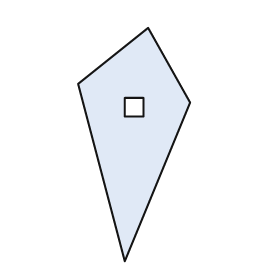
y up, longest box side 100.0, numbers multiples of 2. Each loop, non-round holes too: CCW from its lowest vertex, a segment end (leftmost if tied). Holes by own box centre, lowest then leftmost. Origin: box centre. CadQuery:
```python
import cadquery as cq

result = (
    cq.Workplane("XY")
    .moveTo(-4.0, -50.0)
    .lineTo(24.0, 18.0)
    .lineTo(6.0, 50.0)
    .lineTo(-24.0, 26.0)
    .close()
    .moveTo(-4.0, 12.0)
    .lineTo(4.0, 12.0)
    .lineTo(4.0, 20.0)
    .lineTo(-4.0, 20.0)
    .close()
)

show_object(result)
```